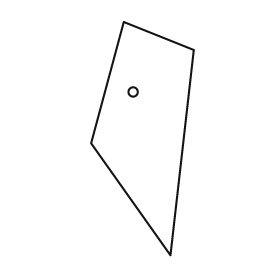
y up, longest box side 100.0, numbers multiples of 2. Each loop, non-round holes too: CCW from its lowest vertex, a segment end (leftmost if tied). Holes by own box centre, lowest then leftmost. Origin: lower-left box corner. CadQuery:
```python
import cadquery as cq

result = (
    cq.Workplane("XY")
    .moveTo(34.0, 0.0)
    .lineTo(44.0, 88.0)
    .lineTo(14.0, 100.0)
    .lineTo(0.0, 48.0)
    .close()
    .moveTo(18.0, 70.0)
    .circle(2.0)
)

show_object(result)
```